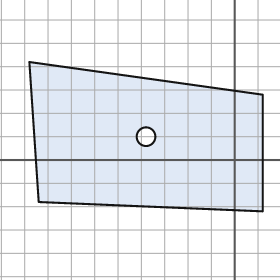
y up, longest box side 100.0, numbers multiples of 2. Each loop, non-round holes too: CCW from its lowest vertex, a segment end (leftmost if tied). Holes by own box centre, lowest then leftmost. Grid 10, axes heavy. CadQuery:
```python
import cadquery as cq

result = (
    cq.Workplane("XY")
    .moveTo(12.0, -22.0)
    .lineTo(12.0, 28.0)
    .lineTo(-88.0, 42.0)
    .lineTo(-84.0, -18.0)
    .close()
    .moveTo(-38.0, 10.0)
    .circle(4.0)
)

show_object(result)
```